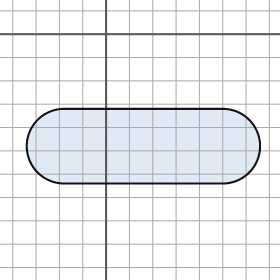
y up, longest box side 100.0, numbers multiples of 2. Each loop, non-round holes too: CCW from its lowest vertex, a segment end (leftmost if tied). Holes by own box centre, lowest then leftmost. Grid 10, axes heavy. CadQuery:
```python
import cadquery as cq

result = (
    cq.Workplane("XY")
    .moveTo(-18.0, -64.0)
    .lineTo(50.0, -64.0)
    .threePointArc((66.0, -48.0), (50.0, -32.0))
    .lineTo(-18.0, -32.0)
    .threePointArc((-34.0, -48.0), (-18.0, -64.0))
    .close()
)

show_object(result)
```